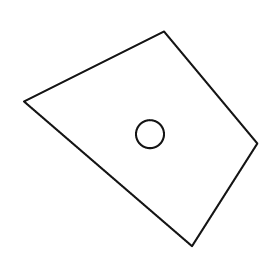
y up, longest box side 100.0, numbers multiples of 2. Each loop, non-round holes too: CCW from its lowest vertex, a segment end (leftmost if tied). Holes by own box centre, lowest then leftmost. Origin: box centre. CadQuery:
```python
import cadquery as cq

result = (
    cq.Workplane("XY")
    .moveTo(22.0, -46.0)
    .lineTo(50.0, -2.0)
    .lineTo(10.0, 46.0)
    .lineTo(-50.0, 16.0)
    .close()
    .moveTo(4.0, 2.0)
    .circle(6.0)
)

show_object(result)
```